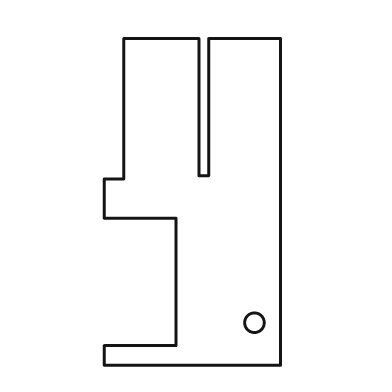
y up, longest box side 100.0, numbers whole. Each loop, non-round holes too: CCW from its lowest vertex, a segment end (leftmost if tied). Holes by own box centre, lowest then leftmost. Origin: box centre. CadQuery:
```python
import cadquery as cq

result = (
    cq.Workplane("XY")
    .moveTo(-27.0, -50.0)
    .lineTo(27.0, -50.0)
    .lineTo(27.0, 50.0)
    .lineTo(5.0, 50.0)
    .lineTo(5.0, 8.0)
    .lineTo(2.0, 8.0)
    .lineTo(2.0, 50.0)
    .lineTo(-21.0, 50.0)
    .lineTo(-21.0, 7.0)
    .lineTo(-27.0, 7.0)
    .lineTo(-27.0, -5.0)
    .lineTo(-5.0, -5.0)
    .lineTo(-5.0, -44.0)
    .lineTo(-27.0, -44.0)
    .close()
    .moveTo(19.0, -37.0)
    .circle(3.0)
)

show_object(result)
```